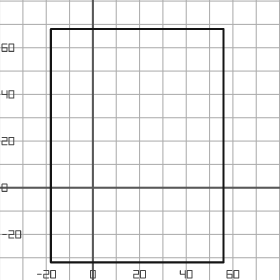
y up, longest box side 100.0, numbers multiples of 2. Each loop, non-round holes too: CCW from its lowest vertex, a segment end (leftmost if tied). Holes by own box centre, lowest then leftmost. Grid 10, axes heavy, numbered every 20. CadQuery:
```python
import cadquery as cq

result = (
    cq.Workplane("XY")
    .moveTo(-18.0, -32.0)
    .lineTo(56.0, -32.0)
    .lineTo(56.0, 68.0)
    .lineTo(-18.0, 68.0)
    .close()
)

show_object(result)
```